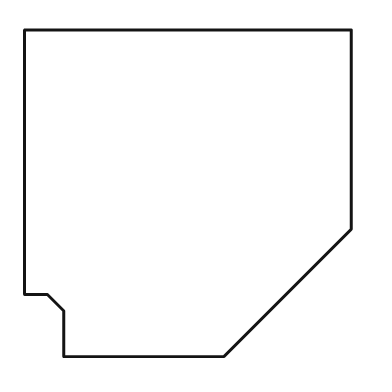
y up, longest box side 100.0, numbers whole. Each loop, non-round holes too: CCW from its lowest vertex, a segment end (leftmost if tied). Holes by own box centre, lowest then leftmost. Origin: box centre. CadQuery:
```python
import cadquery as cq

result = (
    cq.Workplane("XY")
    .moveTo(-38.0, -50.0)
    .lineTo(11.0, -50.0)
    .lineTo(50.0, -11.0)
    .lineTo(50.0, 50.0)
    .lineTo(-50.0, 50.0)
    .lineTo(-50.0, -31.0)
    .lineTo(-43.0, -31.0)
    .lineTo(-38.0, -36.0)
    .close()
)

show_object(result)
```